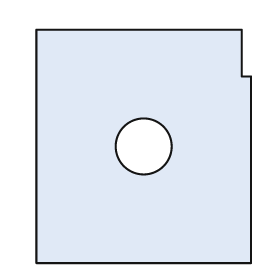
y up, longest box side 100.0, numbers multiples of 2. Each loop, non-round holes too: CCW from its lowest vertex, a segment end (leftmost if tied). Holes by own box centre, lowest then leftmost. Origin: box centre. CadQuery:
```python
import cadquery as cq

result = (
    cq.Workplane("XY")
    .moveTo(-46.0, -50.0)
    .lineTo(46.0, -50.0)
    .lineTo(46.0, 30.0)
    .lineTo(42.0, 30.0)
    .lineTo(42.0, 50.0)
    .lineTo(-46.0, 50.0)
    .close()
    .moveTo(0.0, 0.0)
    .circle(12.0)
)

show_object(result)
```